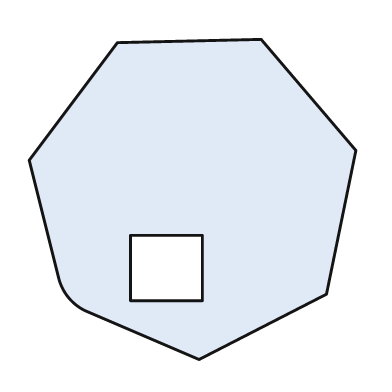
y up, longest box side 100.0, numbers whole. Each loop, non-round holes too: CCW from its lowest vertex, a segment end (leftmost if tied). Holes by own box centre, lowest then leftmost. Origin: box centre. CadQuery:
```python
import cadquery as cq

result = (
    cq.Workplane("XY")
    .moveTo(2.0, -49.0)
    .lineTo(41.0, -29.0)
    .lineTo(50.0, 15.0)
    .lineTo(21.0, 49.0)
    .lineTo(-23.0, 48.0)
    .lineTo(-50.0, 12.0)
    .lineTo(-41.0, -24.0)
    .threePointArc((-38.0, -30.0), (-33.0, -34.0))
    .close()
    .moveTo(-19.0, -31.0)
    .lineTo(3.0, -31.0)
    .lineTo(3.0, -11.0)
    .lineTo(-19.0, -11.0)
    .close()
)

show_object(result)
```